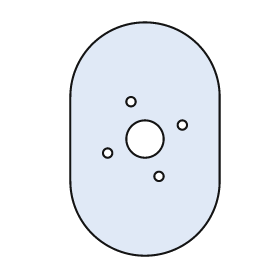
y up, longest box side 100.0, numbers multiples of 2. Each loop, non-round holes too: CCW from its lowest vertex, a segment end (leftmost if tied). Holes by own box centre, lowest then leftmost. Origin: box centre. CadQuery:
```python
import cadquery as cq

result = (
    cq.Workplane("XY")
    .moveTo(-32.0, -18.0)
    .threePointArc((0.0, -50.0), (32.0, -18.0))
    .lineTo(32.0, 18.0)
    .threePointArc((0.0, 50.0), (-32.0, 18.0))
    .close()
    .moveTo(6.0, -16.0)
    .circle(2.0)
    .moveTo(-16.0, -6.0)
    .circle(2.0)
    .moveTo(0.0, 0.0)
    .circle(8.0)
    .moveTo(16.0, 6.0)
    .circle(2.0)
    .moveTo(-6.0, 16.0)
    .circle(2.0)
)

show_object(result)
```